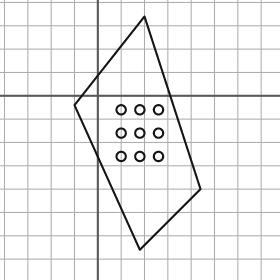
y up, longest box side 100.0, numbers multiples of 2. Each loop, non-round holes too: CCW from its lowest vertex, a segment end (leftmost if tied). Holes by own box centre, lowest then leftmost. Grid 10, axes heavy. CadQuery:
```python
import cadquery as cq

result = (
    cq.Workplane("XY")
    .moveTo(18.0, -66.0)
    .lineTo(44.0, -40.0)
    .lineTo(20.0, 34.0)
    .lineTo(-10.0, -4.0)
    .close()
    .moveTo(10.0, -26.0)
    .circle(2.0)
    .moveTo(18.0, -26.0)
    .circle(2.0)
    .moveTo(26.0, -26.0)
    .circle(2.0)
    .moveTo(10.0, -16.0)
    .circle(2.0)
    .moveTo(18.0, -16.0)
    .circle(2.0)
    .moveTo(26.0, -16.0)
    .circle(2.0)
    .moveTo(10.0, -6.0)
    .circle(2.0)
    .moveTo(18.0, -6.0)
    .circle(2.0)
    .moveTo(26.0, -6.0)
    .circle(2.0)
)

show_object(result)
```